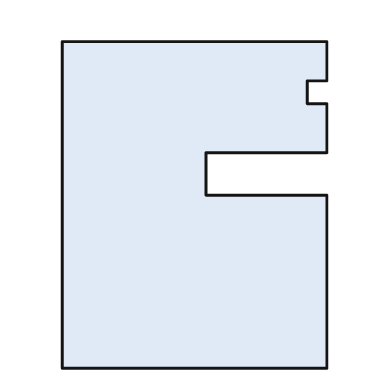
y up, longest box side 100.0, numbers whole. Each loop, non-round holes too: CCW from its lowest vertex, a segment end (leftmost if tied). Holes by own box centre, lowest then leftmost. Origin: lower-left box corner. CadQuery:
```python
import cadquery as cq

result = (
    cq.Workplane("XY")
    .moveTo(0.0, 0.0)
    .lineTo(81.0, 0.0)
    .lineTo(81.0, 53.0)
    .lineTo(44.0, 53.0)
    .lineTo(44.0, 66.0)
    .lineTo(81.0, 66.0)
    .lineTo(81.0, 81.0)
    .lineTo(75.0, 81.0)
    .lineTo(75.0, 88.0)
    .lineTo(81.0, 88.0)
    .lineTo(81.0, 100.0)
    .lineTo(0.0, 100.0)
    .close()
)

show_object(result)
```